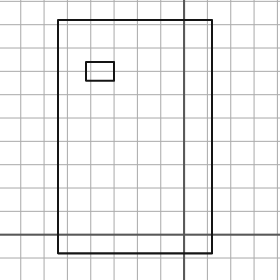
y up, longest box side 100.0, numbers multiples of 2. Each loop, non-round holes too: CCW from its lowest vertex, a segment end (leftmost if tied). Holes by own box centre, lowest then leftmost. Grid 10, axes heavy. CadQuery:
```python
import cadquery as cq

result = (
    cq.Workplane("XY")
    .moveTo(-54.0, -8.0)
    .lineTo(12.0, -8.0)
    .lineTo(12.0, 92.0)
    .lineTo(-54.0, 92.0)
    .close()
    .moveTo(-42.0, 66.0)
    .lineTo(-30.0, 66.0)
    .lineTo(-30.0, 74.0)
    .lineTo(-42.0, 74.0)
    .close()
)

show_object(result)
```